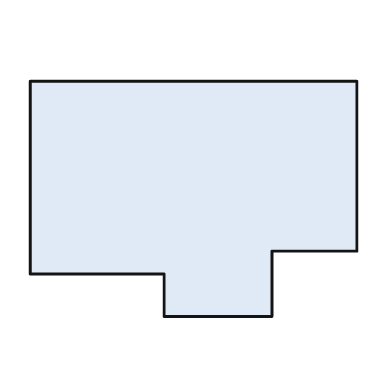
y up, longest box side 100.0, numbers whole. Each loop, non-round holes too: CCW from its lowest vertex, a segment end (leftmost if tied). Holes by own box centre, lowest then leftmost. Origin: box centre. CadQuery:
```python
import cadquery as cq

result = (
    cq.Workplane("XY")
    .moveTo(-9.0, -36.0)
    .lineTo(24.0, -36.0)
    .lineTo(24.0, -16.0)
    .lineTo(50.0, -16.0)
    .lineTo(50.0, 36.0)
    .lineTo(-50.0, 36.0)
    .lineTo(-50.0, -23.0)
    .lineTo(-9.0, -23.0)
    .close()
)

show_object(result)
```